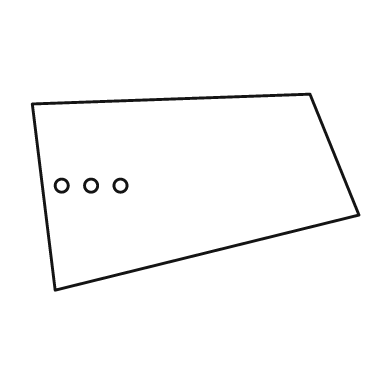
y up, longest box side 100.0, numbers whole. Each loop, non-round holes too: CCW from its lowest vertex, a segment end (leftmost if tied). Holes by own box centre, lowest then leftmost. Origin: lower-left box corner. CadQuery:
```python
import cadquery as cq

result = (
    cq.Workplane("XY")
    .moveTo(7.0, 0.0)
    .lineTo(100.0, 23.0)
    .lineTo(85.0, 60.0)
    .lineTo(0.0, 57.0)
    .close()
    .moveTo(9.0, 32.0)
    .circle(2.0)
    .moveTo(18.0, 32.0)
    .circle(2.0)
    .moveTo(27.0, 32.0)
    .circle(2.0)
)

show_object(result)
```